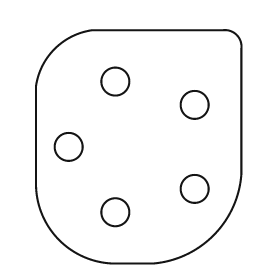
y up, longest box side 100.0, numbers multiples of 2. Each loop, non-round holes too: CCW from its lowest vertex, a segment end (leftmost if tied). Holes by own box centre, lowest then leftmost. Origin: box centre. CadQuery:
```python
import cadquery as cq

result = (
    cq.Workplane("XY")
    .moveTo(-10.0, -50.0)
    .lineTo(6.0, -50.0)
    .threePointArc((32.0, -38.0), (44.0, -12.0))
    .lineTo(44.0, 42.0)
    .threePointArc((42.0, 48.0), (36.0, 50.0))
    .lineTo(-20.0, 50.0)
    .threePointArc((-36.0, 42.0), (-44.0, 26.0))
    .lineTo(-44.0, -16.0)
    .threePointArc((-34.0, -40.0), (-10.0, -50.0))
    .close()
    .moveTo(-10.0, -28.0)
    .circle(6.0)
    .moveTo(24.0, -18.0)
    .circle(6.0)
    .moveTo(-30.0, 0.0)
    .circle(6.0)
    .moveTo(24.0, 18.0)
    .circle(6.0)
    .moveTo(-10.0, 28.0)
    .circle(6.0)
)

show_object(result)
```